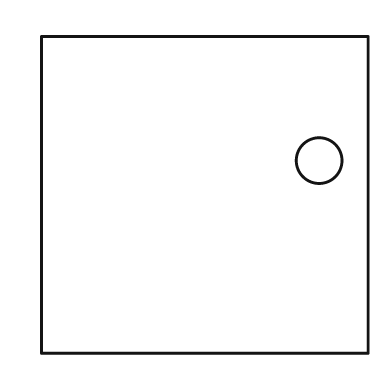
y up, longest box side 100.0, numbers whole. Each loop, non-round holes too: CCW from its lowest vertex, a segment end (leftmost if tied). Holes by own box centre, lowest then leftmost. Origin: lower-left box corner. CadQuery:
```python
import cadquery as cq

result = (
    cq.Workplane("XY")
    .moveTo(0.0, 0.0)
    .lineTo(100.0, 0.0)
    .lineTo(100.0, 97.0)
    .lineTo(0.0, 97.0)
    .close()
    .moveTo(85.0, 59.0)
    .circle(7.0)
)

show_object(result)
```